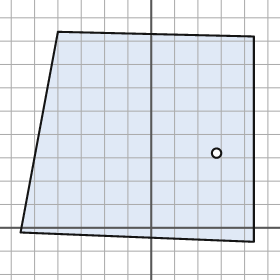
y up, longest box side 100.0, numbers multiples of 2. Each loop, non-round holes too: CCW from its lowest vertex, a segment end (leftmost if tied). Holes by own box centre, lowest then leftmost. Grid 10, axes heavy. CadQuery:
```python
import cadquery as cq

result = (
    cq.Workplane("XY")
    .moveTo(44.0, -6.0)
    .lineTo(44.0, 82.0)
    .lineTo(-40.0, 84.0)
    .lineTo(-56.0, -2.0)
    .close()
    .moveTo(28.0, 32.0)
    .circle(2.0)
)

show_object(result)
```